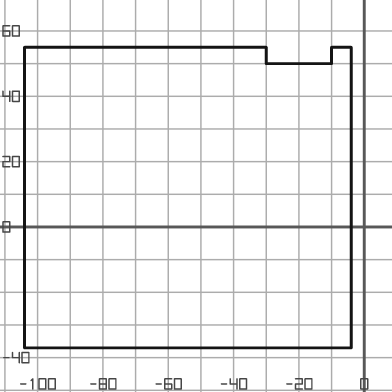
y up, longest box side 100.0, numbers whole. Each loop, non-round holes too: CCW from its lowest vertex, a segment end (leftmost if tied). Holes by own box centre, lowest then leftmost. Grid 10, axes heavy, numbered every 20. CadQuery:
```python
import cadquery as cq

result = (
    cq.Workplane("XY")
    .moveTo(-104.0, -37.0)
    .lineTo(-4.0, -37.0)
    .lineTo(-4.0, 55.0)
    .lineTo(-10.0, 55.0)
    .lineTo(-10.0, 50.0)
    .lineTo(-30.0, 50.0)
    .lineTo(-30.0, 55.0)
    .lineTo(-104.0, 55.0)
    .close()
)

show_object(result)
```